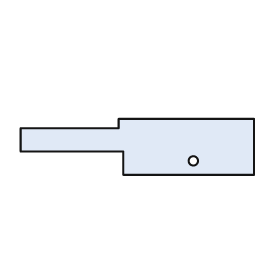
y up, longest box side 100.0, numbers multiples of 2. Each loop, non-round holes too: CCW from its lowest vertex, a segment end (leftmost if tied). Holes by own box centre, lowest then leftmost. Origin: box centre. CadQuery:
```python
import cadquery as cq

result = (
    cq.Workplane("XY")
    .moveTo(-6.0, -12.0)
    .lineTo(50.0, -12.0)
    .lineTo(50.0, 12.0)
    .lineTo(-8.0, 12.0)
    .lineTo(-8.0, 8.0)
    .lineTo(-50.0, 8.0)
    .lineTo(-50.0, -2.0)
    .lineTo(-6.0, -2.0)
    .close()
    .moveTo(24.0, -6.0)
    .circle(2.0)
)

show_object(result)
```